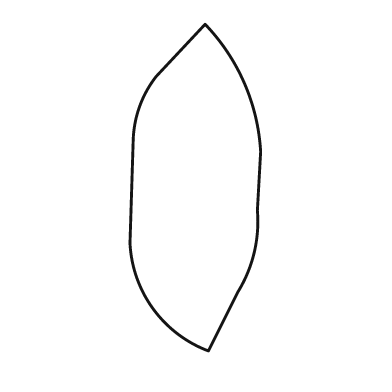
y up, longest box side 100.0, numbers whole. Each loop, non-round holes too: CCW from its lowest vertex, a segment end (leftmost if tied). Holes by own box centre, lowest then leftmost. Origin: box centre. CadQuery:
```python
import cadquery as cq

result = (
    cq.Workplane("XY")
    .moveTo(4.0, -50.0)
    .lineTo(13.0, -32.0)
    .threePointArc((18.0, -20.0), (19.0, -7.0))
    .lineTo(20.0, 11.0)
    .threePointArc((15.0, 32.0), (3.0, 50.0))
    .lineTo(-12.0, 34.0)
    .threePointArc((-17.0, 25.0), (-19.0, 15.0))
    .lineTo(-20.0, -17.0)
    .threePointArc((-13.0, -37.0), (4.0, -50.0))
    .close()
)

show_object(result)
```